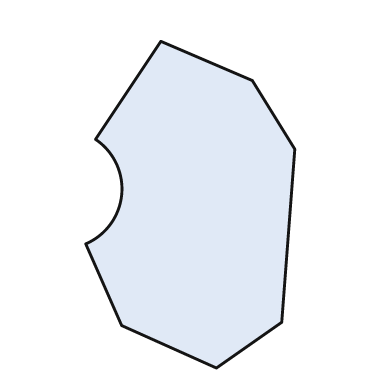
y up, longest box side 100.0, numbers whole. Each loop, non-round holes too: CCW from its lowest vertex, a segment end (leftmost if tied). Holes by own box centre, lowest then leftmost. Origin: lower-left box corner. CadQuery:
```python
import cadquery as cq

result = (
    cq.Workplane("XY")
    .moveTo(40.0, 0.0)
    .lineTo(60.0, 14.0)
    .lineTo(64.0, 67.0)
    .lineTo(51.0, 88.0)
    .lineTo(23.0, 100.0)
    .lineTo(3.0, 70.0)
    .threePointArc((11.0, 53.0), (0.0, 38.0))
    .lineTo(11.0, 13.0)
    .close()
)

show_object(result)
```